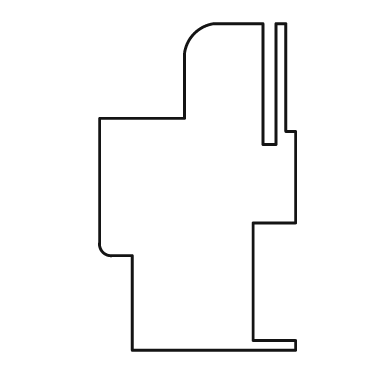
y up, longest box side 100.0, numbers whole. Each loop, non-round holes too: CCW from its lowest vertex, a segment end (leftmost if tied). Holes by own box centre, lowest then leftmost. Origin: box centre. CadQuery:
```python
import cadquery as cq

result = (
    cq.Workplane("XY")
    .moveTo(-20.0, -50.0)
    .lineTo(30.0, -50.0)
    .lineTo(30.0, -47.0)
    .lineTo(17.0, -47.0)
    .lineTo(17.0, -11.0)
    .lineTo(30.0, -11.0)
    .lineTo(30.0, 17.0)
    .lineTo(27.0, 17.0)
    .lineTo(27.0, 50.0)
    .lineTo(24.0, 50.0)
    .lineTo(24.0, 13.0)
    .lineTo(20.0, 13.0)
    .lineTo(20.0, 50.0)
    .lineTo(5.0, 50.0)
    .threePointArc((-1.0, 47.0), (-4.0, 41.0))
    .lineTo(-4.0, 21.0)
    .lineTo(-30.0, 21.0)
    .lineTo(-30.0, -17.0)
    .threePointArc((-29.0, -20.0), (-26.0, -21.0))
    .lineTo(-20.0, -21.0)
    .close()
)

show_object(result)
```